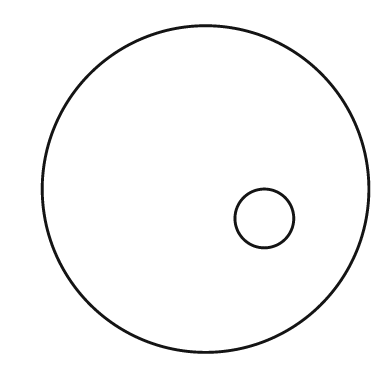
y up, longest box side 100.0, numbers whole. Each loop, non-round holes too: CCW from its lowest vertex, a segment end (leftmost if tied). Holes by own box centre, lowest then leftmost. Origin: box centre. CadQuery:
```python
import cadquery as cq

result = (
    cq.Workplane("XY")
    .moveTo(0.0, 0.0)
    .circle(50.0)
    .moveTo(18.0, -9.0)
    .circle(9.0)
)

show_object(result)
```